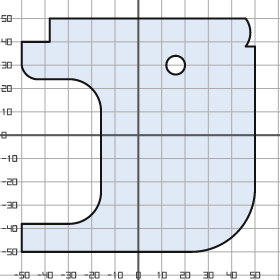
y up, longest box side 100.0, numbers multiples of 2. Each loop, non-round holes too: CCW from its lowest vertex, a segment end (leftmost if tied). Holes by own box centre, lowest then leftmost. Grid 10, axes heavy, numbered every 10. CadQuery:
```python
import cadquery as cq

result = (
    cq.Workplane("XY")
    .moveTo(-50.0, -50.0)
    .lineTo(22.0, -50.0)
    .threePointArc((42.0, -42.0), (50.0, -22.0))
    .lineTo(50.0, 38.0)
    .lineTo(46.0, 38.0)
    .threePointArc((48.0, 44.0), (46.0, 50.0))
    .lineTo(-38.0, 50.0)
    .lineTo(-38.0, 40.0)
    .lineTo(-50.0, 40.0)
    .lineTo(-50.0, 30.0)
    .threePointArc((-48.0, 26.0), (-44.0, 24.0))
    .lineTo(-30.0, 24.0)
    .threePointArc((-20.0, 20.0), (-16.0, 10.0))
    .lineTo(-16.0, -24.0)
    .threePointArc((-20.0, -34.0), (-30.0, -38.0))
    .lineTo(-50.0, -38.0)
    .close()
    .moveTo(16.0, 30.0)
    .circle(4.0)
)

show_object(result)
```